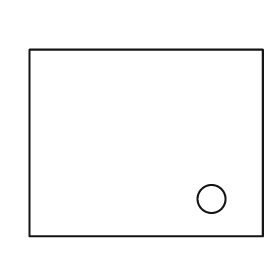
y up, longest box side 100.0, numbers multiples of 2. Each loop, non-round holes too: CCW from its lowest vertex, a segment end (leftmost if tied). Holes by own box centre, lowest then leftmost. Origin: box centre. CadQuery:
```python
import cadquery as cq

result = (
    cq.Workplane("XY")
    .moveTo(-50.0, -40.0)
    .lineTo(50.0, -40.0)
    .lineTo(50.0, 40.0)
    .lineTo(-50.0, 40.0)
    .close()
    .moveTo(28.0, -24.0)
    .circle(6.0)
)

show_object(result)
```